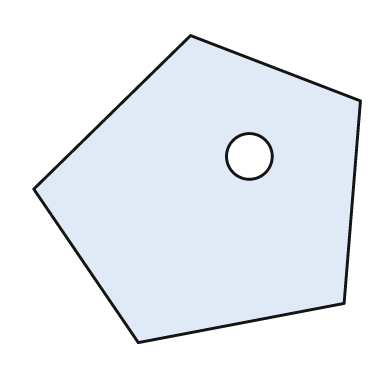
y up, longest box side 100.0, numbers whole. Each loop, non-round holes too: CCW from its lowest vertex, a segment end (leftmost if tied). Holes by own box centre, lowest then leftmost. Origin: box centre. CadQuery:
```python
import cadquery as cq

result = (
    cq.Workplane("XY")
    .moveTo(-18.0, -47.0)
    .lineTo(45.0, -35.0)
    .lineTo(50.0, 27.0)
    .lineTo(-2.0, 47.0)
    .lineTo(-50.0, 0.0)
    .close()
    .moveTo(16.0, 10.0)
    .circle(7.0)
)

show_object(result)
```